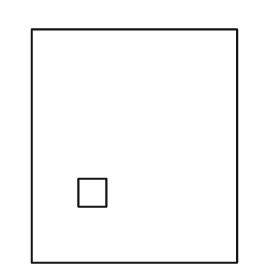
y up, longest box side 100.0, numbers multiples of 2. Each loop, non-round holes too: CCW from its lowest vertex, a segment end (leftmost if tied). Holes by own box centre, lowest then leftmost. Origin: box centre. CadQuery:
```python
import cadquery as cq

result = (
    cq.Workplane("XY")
    .moveTo(-44.0, -50.0)
    .lineTo(44.0, -50.0)
    .lineTo(44.0, 50.0)
    .lineTo(-44.0, 50.0)
    .close()
    .moveTo(-24.0, -26.0)
    .lineTo(-12.0, -26.0)
    .lineTo(-12.0, -14.0)
    .lineTo(-24.0, -14.0)
    .close()
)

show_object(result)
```